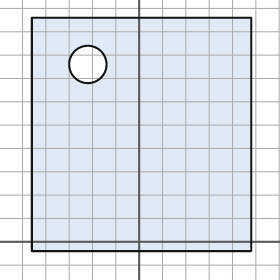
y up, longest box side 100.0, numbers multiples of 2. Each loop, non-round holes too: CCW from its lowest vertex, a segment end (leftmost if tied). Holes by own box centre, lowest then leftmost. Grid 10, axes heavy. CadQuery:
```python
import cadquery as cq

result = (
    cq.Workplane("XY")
    .moveTo(-46.0, -4.0)
    .lineTo(48.0, -4.0)
    .lineTo(48.0, 96.0)
    .lineTo(-46.0, 96.0)
    .close()
    .moveTo(-22.0, 76.0)
    .circle(8.0)
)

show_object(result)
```